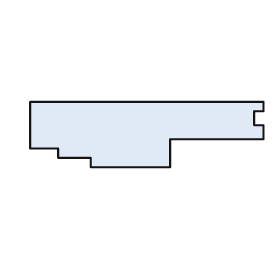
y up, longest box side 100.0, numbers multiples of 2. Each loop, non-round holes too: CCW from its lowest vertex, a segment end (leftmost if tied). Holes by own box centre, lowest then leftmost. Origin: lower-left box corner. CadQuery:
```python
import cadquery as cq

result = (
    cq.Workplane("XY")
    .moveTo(26.0, 0.0)
    .lineTo(60.0, 0.0)
    .lineTo(60.0, 12.0)
    .lineTo(100.0, 12.0)
    .lineTo(100.0, 18.0)
    .lineTo(96.0, 18.0)
    .lineTo(96.0, 24.0)
    .lineTo(100.0, 24.0)
    .lineTo(100.0, 28.0)
    .lineTo(0.0, 28.0)
    .lineTo(0.0, 8.0)
    .lineTo(12.0, 8.0)
    .lineTo(12.0, 4.0)
    .lineTo(26.0, 4.0)
    .close()
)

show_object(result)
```